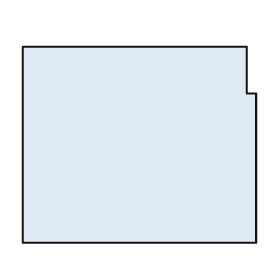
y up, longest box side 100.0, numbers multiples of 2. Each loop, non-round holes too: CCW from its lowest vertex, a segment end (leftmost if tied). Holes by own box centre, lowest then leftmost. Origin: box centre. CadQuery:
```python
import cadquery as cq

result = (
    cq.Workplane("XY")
    .moveTo(-50.0, -42.0)
    .lineTo(50.0, -42.0)
    .lineTo(50.0, 22.0)
    .lineTo(46.0, 22.0)
    .lineTo(46.0, 42.0)
    .lineTo(-50.0, 42.0)
    .close()
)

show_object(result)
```